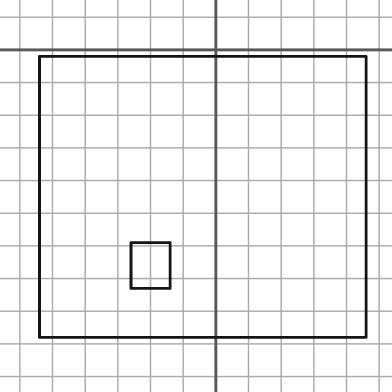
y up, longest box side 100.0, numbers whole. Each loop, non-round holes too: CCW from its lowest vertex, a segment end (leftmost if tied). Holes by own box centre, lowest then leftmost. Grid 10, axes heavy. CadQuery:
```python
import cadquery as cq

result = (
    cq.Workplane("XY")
    .moveTo(-54.0, -88.0)
    .lineTo(46.0, -88.0)
    .lineTo(46.0, -2.0)
    .lineTo(-54.0, -2.0)
    .close()
    .moveTo(-26.0, -73.0)
    .lineTo(-14.0, -73.0)
    .lineTo(-14.0, -59.0)
    .lineTo(-26.0, -59.0)
    .close()
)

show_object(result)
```